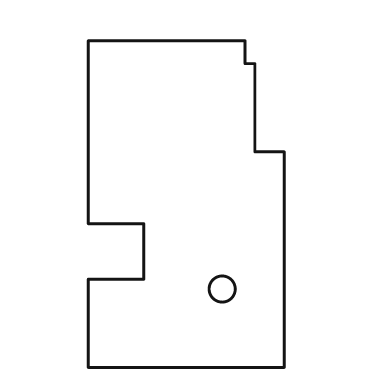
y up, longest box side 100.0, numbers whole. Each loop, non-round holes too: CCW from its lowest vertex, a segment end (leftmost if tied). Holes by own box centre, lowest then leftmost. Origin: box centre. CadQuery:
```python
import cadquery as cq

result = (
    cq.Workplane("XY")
    .moveTo(-30.0, -50.0)
    .lineTo(30.0, -50.0)
    .lineTo(30.0, 16.0)
    .lineTo(21.0, 16.0)
    .lineTo(21.0, 43.0)
    .lineTo(18.0, 43.0)
    .lineTo(18.0, 50.0)
    .lineTo(-30.0, 50.0)
    .lineTo(-30.0, -6.0)
    .lineTo(-13.0, -6.0)
    .lineTo(-13.0, -23.0)
    .lineTo(-30.0, -23.0)
    .close()
    .moveTo(11.0, -26.0)
    .circle(4.0)
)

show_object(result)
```